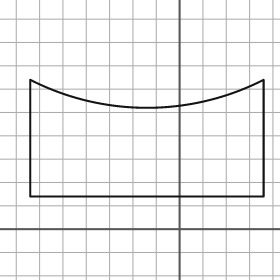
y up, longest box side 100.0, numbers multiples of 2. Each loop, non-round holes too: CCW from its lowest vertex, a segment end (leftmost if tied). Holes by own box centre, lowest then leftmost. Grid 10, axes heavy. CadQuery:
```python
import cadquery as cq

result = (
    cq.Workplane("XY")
    .moveTo(-64.0, 14.0)
    .lineTo(36.0, 14.0)
    .lineTo(36.0, 64.0)
    .threePointArc((-14.0, 52.0), (-64.0, 64.0))
    .close()
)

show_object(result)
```